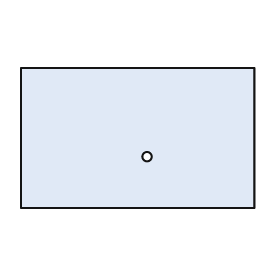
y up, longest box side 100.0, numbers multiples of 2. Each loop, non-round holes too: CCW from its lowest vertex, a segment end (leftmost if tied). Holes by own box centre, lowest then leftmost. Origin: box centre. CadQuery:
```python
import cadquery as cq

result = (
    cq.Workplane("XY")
    .moveTo(-50.0, -30.0)
    .lineTo(50.0, -30.0)
    .lineTo(50.0, 30.0)
    .lineTo(-50.0, 30.0)
    .close()
    .moveTo(4.0, -8.0)
    .circle(2.0)
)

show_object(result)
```